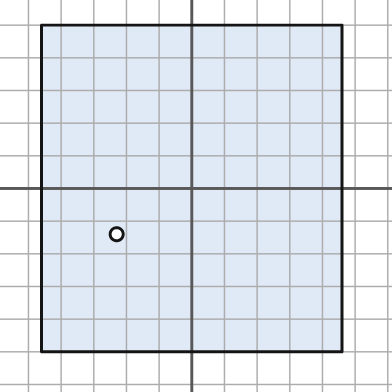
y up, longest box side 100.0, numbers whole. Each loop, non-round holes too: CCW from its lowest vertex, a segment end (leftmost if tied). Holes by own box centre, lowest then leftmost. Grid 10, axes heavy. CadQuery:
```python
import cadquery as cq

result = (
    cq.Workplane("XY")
    .moveTo(-46.0, -50.0)
    .lineTo(46.0, -50.0)
    .lineTo(46.0, 50.0)
    .lineTo(-46.0, 50.0)
    .close()
    .moveTo(-23.0, -14.0)
    .circle(2.0)
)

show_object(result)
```